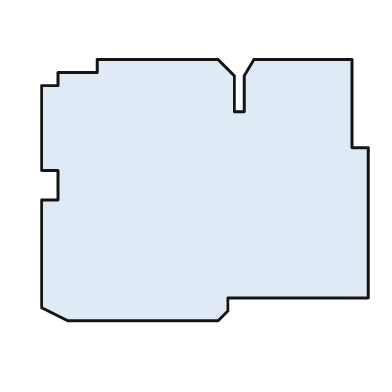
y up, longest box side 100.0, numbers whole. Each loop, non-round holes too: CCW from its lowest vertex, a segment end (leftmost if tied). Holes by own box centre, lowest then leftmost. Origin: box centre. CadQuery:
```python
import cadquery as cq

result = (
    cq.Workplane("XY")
    .moveTo(-42.0, -40.0)
    .lineTo(4.0, -40.0)
    .lineTo(7.0, -37.0)
    .lineTo(7.0, -33.0)
    .lineTo(50.0, -33.0)
    .lineTo(50.0, 13.0)
    .lineTo(45.0, 13.0)
    .lineTo(45.0, 40.0)
    .lineTo(15.0, 40.0)
    .lineTo(12.0, 35.0)
    .lineTo(12.0, 24.0)
    .lineTo(9.0, 24.0)
    .lineTo(9.0, 35.0)
    .lineTo(4.0, 40.0)
    .lineTo(-33.0, 40.0)
    .lineTo(-33.0, 36.0)
    .lineTo(-45.0, 36.0)
    .lineTo(-45.0, 32.0)
    .lineTo(-50.0, 32.0)
    .lineTo(-50.0, 6.0)
    .lineTo(-45.0, 6.0)
    .lineTo(-45.0, -3.0)
    .lineTo(-50.0, -3.0)
    .lineTo(-50.0, -36.0)
    .close()
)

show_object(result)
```